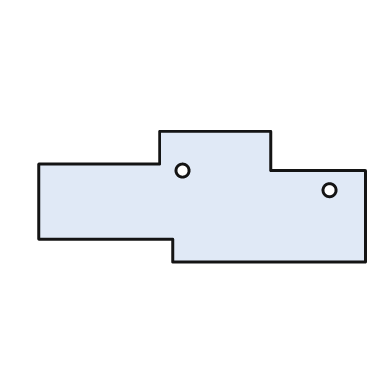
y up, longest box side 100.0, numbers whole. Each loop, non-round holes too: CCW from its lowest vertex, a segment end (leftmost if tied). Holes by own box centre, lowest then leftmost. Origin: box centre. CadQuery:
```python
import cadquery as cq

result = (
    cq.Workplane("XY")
    .moveTo(-9.0, -20.0)
    .lineTo(50.0, -20.0)
    .lineTo(50.0, 8.0)
    .lineTo(21.0, 8.0)
    .lineTo(21.0, 20.0)
    .lineTo(-13.0, 20.0)
    .lineTo(-13.0, 10.0)
    .lineTo(-50.0, 10.0)
    .lineTo(-50.0, -13.0)
    .lineTo(-9.0, -13.0)
    .close()
    .moveTo(39.0, 2.0)
    .circle(2.0)
    .moveTo(-6.0, 8.0)
    .circle(2.0)
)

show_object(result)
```